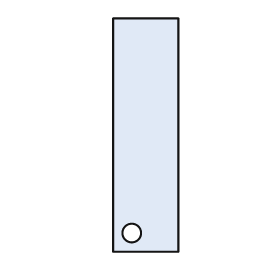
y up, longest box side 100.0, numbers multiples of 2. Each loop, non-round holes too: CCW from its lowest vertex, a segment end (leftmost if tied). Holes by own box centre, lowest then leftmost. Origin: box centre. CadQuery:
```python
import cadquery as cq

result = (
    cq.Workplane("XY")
    .moveTo(-14.0, -50.0)
    .lineTo(14.0, -50.0)
    .lineTo(14.0, 50.0)
    .lineTo(-14.0, 50.0)
    .close()
    .moveTo(-6.0, -42.0)
    .circle(4.0)
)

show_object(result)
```